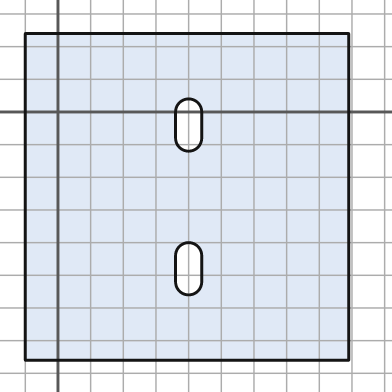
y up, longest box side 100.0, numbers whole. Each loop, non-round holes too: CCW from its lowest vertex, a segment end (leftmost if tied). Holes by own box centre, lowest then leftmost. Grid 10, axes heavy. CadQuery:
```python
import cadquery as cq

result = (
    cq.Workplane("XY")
    .moveTo(-10.0, -76.0)
    .lineTo(89.0, -76.0)
    .lineTo(89.0, 24.0)
    .lineTo(-10.0, 24.0)
    .close()
    .moveTo(36.0, -52.0)
    .threePointArc((40.0, -56.0), (44.0, -52.0))
    .lineTo(44.0, -44.0)
    .threePointArc((40.0, -40.0), (36.0, -44.0))
    .close()
    .moveTo(36.0, -8.0)
    .threePointArc((40.0, -12.0), (44.0, -8.0))
    .lineTo(44.0, 0.0)
    .threePointArc((40.0, 4.0), (36.0, 0.0))
    .close()
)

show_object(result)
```